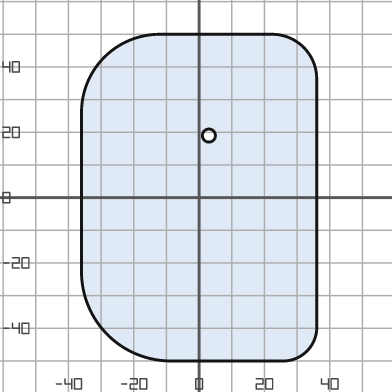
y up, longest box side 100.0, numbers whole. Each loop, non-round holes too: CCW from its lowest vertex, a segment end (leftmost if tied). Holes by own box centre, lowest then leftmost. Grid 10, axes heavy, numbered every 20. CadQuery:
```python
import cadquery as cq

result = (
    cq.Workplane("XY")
    .moveTo(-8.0, -50.0)
    .lineTo(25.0, -50.0)
    .threePointArc((33.0, -47.0), (36.0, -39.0))
    .lineTo(36.0, 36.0)
    .threePointArc((32.0, 46.0), (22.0, 50.0))
    .lineTo(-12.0, 50.0)
    .threePointArc((-29.0, 43.0), (-36.0, 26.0))
    .lineTo(-36.0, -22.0)
    .threePointArc((-28.0, -42.0), (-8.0, -50.0))
    .close()
    .moveTo(3.0, 19.0)
    .circle(2.0)
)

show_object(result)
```